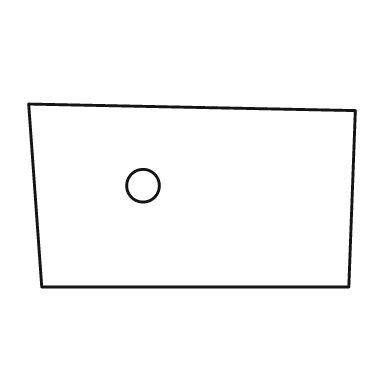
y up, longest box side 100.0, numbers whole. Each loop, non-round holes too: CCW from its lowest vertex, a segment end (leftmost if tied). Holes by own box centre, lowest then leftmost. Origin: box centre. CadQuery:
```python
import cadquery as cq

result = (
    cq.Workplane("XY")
    .moveTo(-46.0, -28.0)
    .lineTo(48.0, -28.0)
    .lineTo(50.0, 26.0)
    .lineTo(-50.0, 28.0)
    .close()
    .moveTo(-15.0, 3.0)
    .circle(5.0)
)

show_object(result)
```